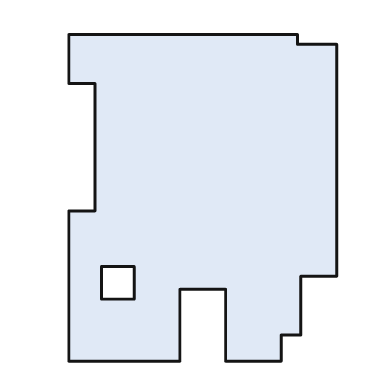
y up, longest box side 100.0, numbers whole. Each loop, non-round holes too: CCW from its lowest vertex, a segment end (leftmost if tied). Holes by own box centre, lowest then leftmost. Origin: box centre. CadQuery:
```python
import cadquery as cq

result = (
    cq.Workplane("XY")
    .moveTo(-41.0, -50.0)
    .lineTo(-7.0, -50.0)
    .lineTo(-7.0, -28.0)
    .lineTo(7.0, -28.0)
    .lineTo(7.0, -50.0)
    .lineTo(24.0, -50.0)
    .lineTo(24.0, -42.0)
    .lineTo(30.0, -42.0)
    .lineTo(30.0, -24.0)
    .lineTo(41.0, -24.0)
    .lineTo(41.0, 47.0)
    .lineTo(29.0, 47.0)
    .lineTo(29.0, 50.0)
    .lineTo(-41.0, 50.0)
    .lineTo(-41.0, 35.0)
    .lineTo(-33.0, 35.0)
    .lineTo(-33.0, -4.0)
    .lineTo(-41.0, -4.0)
    .close()
    .moveTo(-31.0, -31.0)
    .lineTo(-21.0, -31.0)
    .lineTo(-21.0, -21.0)
    .lineTo(-31.0, -21.0)
    .close()
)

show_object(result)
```